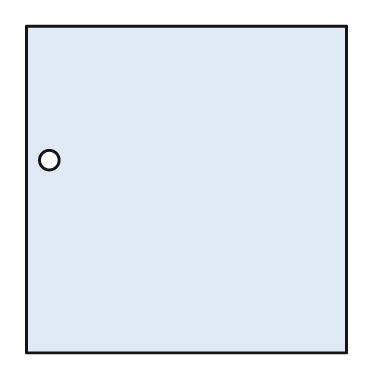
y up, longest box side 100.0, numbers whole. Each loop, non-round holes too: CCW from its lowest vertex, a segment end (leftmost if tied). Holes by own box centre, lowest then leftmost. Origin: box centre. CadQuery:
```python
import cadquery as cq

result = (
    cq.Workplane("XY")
    .moveTo(-49.0, -50.0)
    .lineTo(49.0, -50.0)
    .lineTo(49.0, 50.0)
    .lineTo(-49.0, 50.0)
    .close()
    .moveTo(-42.0, 9.0)
    .circle(3.0)
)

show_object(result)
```